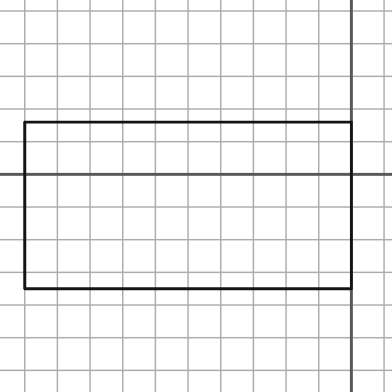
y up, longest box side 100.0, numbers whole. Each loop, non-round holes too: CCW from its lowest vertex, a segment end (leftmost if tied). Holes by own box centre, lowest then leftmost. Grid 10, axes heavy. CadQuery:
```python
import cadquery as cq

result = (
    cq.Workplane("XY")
    .moveTo(-100.0, -35.0)
    .lineTo(0.0, -35.0)
    .lineTo(0.0, 16.0)
    .lineTo(-100.0, 16.0)
    .close()
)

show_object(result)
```